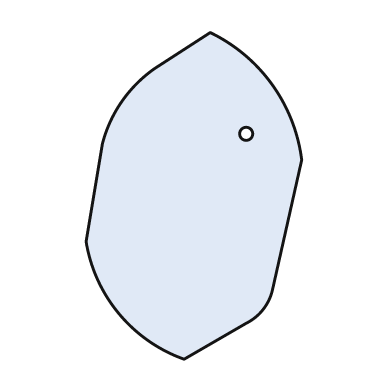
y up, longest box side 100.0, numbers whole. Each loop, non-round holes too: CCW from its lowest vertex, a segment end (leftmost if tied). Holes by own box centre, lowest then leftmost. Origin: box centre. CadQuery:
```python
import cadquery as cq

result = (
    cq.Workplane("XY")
    .moveTo(-3.0, -50.0)
    .lineTo(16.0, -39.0)
    .threePointArc((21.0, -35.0), (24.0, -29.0))
    .lineTo(33.0, 11.0)
    .threePointArc((24.0, 34.0), (5.0, 50.0))
    .lineTo(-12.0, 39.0)
    .threePointArc((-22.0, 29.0), (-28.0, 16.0))
    .lineTo(-33.0, -14.0)
    .threePointArc((-23.0, -36.0), (-3.0, -50.0))
    .close()
    .moveTo(16.0, 19.0)
    .circle(2.0)
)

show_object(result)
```